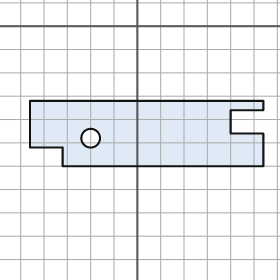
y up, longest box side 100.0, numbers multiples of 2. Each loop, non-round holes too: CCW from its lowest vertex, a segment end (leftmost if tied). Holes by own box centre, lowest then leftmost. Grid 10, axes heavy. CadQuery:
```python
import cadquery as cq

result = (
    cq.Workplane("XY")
    .moveTo(-32.0, -60.0)
    .lineTo(54.0, -60.0)
    .lineTo(54.0, -46.0)
    .lineTo(40.0, -46.0)
    .lineTo(40.0, -36.0)
    .lineTo(54.0, -36.0)
    .lineTo(54.0, -32.0)
    .lineTo(-46.0, -32.0)
    .lineTo(-46.0, -52.0)
    .lineTo(-32.0, -52.0)
    .close()
    .moveTo(-20.0, -48.0)
    .circle(4.0)
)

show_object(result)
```